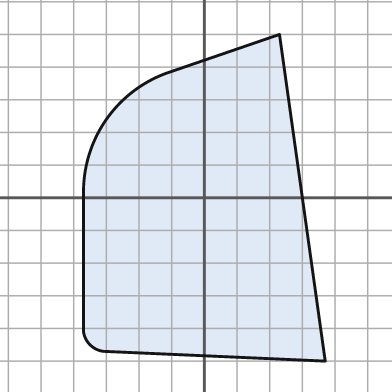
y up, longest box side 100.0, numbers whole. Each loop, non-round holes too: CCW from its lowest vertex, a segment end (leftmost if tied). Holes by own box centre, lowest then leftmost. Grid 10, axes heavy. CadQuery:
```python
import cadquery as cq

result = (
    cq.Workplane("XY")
    .moveTo(37.0, -50.0)
    .lineTo(23.0, 50.0)
    .lineTo(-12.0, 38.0)
    .threePointArc((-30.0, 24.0), (-37.0, 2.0))
    .lineTo(-37.0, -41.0)
    .threePointArc((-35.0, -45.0), (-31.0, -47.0))
    .close()
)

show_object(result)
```